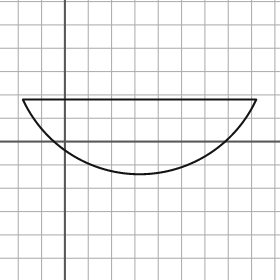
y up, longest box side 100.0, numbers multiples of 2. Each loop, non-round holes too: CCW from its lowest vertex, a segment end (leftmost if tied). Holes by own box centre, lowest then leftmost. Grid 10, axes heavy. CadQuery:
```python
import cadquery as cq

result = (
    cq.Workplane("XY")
    .moveTo(-18.0, 18.0)
    .threePointArc((32.0, -14.0), (82.0, 18.0))
    .close()
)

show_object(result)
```